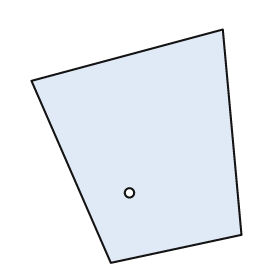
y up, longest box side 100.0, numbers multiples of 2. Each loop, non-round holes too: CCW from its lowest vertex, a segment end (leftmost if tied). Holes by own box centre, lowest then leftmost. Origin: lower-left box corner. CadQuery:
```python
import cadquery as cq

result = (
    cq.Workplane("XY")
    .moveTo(34.0, 0.0)
    .lineTo(90.0, 12.0)
    .lineTo(82.0, 100.0)
    .lineTo(0.0, 78.0)
    .close()
    .moveTo(42.0, 30.0)
    .circle(2.0)
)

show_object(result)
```